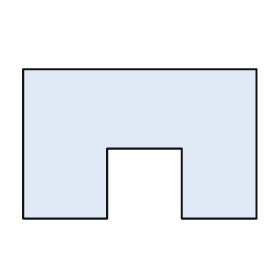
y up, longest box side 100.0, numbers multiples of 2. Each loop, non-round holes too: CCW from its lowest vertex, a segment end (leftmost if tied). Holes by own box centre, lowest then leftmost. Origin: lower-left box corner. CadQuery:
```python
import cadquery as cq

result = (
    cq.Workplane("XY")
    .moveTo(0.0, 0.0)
    .lineTo(36.0, 0.0)
    .lineTo(36.0, 30.0)
    .lineTo(68.0, 30.0)
    .lineTo(68.0, 0.0)
    .lineTo(100.0, 0.0)
    .lineTo(100.0, 64.0)
    .lineTo(0.0, 64.0)
    .close()
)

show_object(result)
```